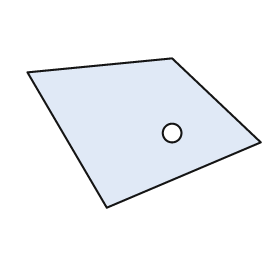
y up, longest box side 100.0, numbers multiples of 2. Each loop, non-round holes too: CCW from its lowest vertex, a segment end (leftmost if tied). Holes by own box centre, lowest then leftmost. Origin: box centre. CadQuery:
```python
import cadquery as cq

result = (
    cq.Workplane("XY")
    .moveTo(-16.0, -32.0)
    .lineTo(50.0, -4.0)
    .lineTo(12.0, 32.0)
    .lineTo(-50.0, 26.0)
    .close()
    .moveTo(12.0, 0.0)
    .circle(4.0)
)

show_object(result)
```